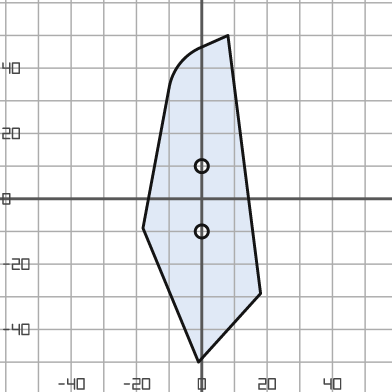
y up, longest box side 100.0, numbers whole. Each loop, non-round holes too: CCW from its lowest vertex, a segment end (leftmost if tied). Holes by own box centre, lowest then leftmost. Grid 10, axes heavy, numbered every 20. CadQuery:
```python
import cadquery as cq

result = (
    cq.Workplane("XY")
    .moveTo(-1.0, -50.0)
    .lineTo(18.0, -29.0)
    .lineTo(8.0, 50.0)
    .lineTo(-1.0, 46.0)
    .threePointArc((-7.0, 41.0), (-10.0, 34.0))
    .lineTo(-18.0, -9.0)
    .close()
    .moveTo(0.0, -10.0)
    .circle(2.0)
    .moveTo(0.0, 10.0)
    .circle(2.0)
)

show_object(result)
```